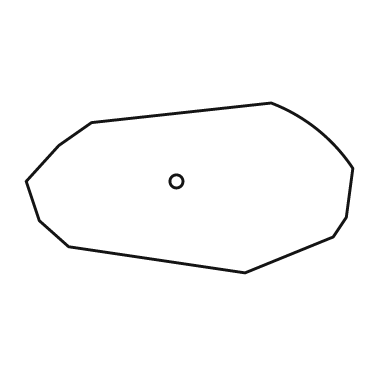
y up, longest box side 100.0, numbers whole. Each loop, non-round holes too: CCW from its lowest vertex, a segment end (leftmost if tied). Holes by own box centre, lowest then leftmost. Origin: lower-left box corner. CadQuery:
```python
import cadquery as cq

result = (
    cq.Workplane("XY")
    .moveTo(67.0, 0.0)
    .lineTo(94.0, 11.0)
    .lineTo(98.0, 17.0)
    .lineTo(100.0, 32.0)
    .threePointArc((89.0, 44.0), (75.0, 52.0))
    .lineTo(20.0, 46.0)
    .lineTo(10.0, 39.0)
    .lineTo(0.0, 28.0)
    .lineTo(4.0, 16.0)
    .lineTo(13.0, 8.0)
    .close()
    .moveTo(46.0, 28.0)
    .circle(2.0)
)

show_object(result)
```